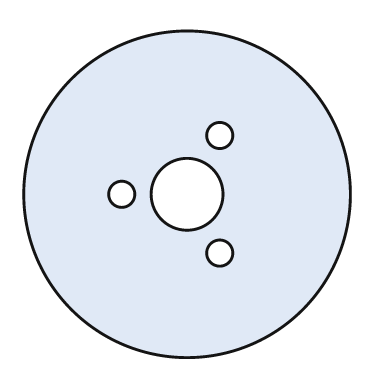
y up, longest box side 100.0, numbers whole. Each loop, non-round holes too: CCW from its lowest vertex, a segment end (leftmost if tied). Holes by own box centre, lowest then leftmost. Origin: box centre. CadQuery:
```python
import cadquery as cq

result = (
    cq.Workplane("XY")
    .moveTo(0.0, 0.0)
    .circle(50.0)
    .moveTo(10.0, -18.0)
    .circle(4.0)
    .moveTo(-20.0, 0.0)
    .circle(4.0)
    .moveTo(0.0, 0.0)
    .circle(11.0)
    .moveTo(10.0, 18.0)
    .circle(4.0)
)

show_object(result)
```